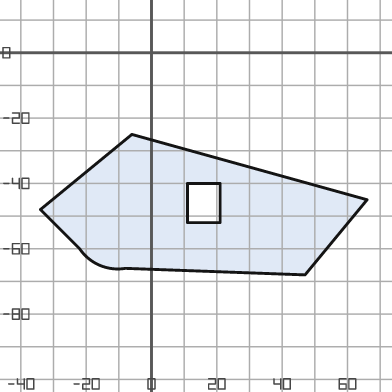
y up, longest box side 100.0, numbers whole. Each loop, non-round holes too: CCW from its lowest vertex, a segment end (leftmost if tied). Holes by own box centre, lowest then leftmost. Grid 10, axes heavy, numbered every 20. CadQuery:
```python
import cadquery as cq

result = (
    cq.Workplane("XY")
    .moveTo(47.0, -68.0)
    .lineTo(66.0, -45.0)
    .lineTo(-6.0, -25.0)
    .lineTo(-34.0, -48.0)
    .lineTo(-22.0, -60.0)
    .threePointArc((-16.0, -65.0), (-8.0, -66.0))
    .close()
    .moveTo(11.0, -52.0)
    .lineTo(21.0, -52.0)
    .lineTo(21.0, -40.0)
    .lineTo(11.0, -40.0)
    .close()
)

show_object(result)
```